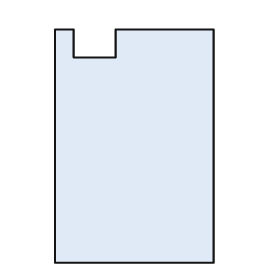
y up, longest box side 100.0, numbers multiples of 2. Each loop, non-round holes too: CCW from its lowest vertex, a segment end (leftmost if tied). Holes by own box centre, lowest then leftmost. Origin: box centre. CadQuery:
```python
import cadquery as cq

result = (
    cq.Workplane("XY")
    .moveTo(-34.0, -50.0)
    .lineTo(34.0, -50.0)
    .lineTo(34.0, 50.0)
    .lineTo(-8.0, 50.0)
    .lineTo(-8.0, 38.0)
    .lineTo(-26.0, 38.0)
    .lineTo(-26.0, 50.0)
    .lineTo(-34.0, 50.0)
    .close()
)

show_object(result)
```